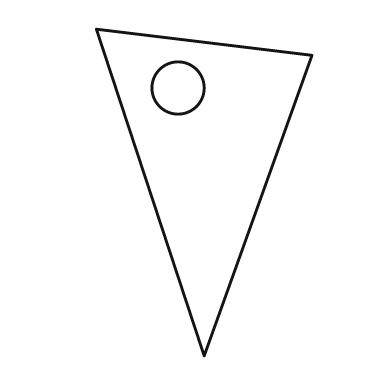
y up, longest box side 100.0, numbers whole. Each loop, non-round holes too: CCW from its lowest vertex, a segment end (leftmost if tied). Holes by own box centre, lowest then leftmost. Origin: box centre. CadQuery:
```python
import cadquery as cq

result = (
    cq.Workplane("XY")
    .moveTo(0.0, -50.0)
    .lineTo(33.0, 42.0)
    .lineTo(-33.0, 50.0)
    .close()
    .moveTo(-8.0, 32.0)
    .circle(8.0)
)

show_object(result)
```